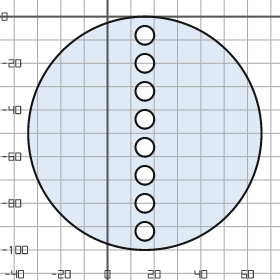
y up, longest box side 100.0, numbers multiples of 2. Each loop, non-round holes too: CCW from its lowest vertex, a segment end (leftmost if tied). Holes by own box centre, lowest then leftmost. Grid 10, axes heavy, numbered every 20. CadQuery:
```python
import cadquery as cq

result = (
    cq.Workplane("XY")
    .moveTo(16.0, -50.0)
    .circle(50.0)
    .moveTo(16.0, -92.0)
    .circle(4.0)
    .moveTo(16.0, -80.0)
    .circle(4.0)
    .moveTo(16.0, -68.0)
    .circle(4.0)
    .moveTo(16.0, -56.0)
    .circle(4.0)
    .moveTo(16.0, -44.0)
    .circle(4.0)
    .moveTo(16.0, -32.0)
    .circle(4.0)
    .moveTo(16.0, -20.0)
    .circle(4.0)
    .moveTo(16.0, -8.0)
    .circle(4.0)
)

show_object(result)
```